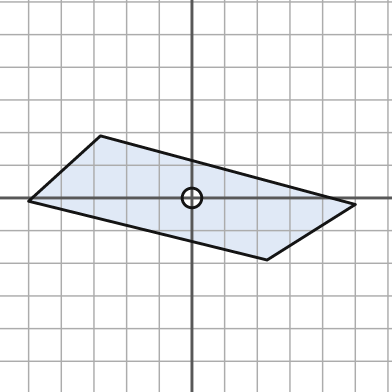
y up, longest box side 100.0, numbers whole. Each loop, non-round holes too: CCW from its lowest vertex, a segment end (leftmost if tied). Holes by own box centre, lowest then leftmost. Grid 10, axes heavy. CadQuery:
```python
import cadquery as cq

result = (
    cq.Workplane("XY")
    .moveTo(23.0, -19.0)
    .lineTo(50.0, -2.0)
    .lineTo(-28.0, 19.0)
    .lineTo(-50.0, -1.0)
    .close()
    .moveTo(0.0, 0.0)
    .circle(3.0)
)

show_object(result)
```